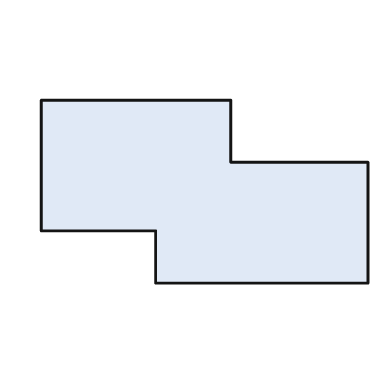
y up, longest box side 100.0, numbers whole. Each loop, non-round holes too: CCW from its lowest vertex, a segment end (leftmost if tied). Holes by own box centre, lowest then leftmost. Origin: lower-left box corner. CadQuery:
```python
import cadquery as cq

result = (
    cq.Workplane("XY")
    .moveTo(35.0, 0.0)
    .lineTo(100.0, 0.0)
    .lineTo(100.0, 37.0)
    .lineTo(58.0, 37.0)
    .lineTo(58.0, 56.0)
    .lineTo(0.0, 56.0)
    .lineTo(0.0, 16.0)
    .lineTo(35.0, 16.0)
    .close()
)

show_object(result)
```